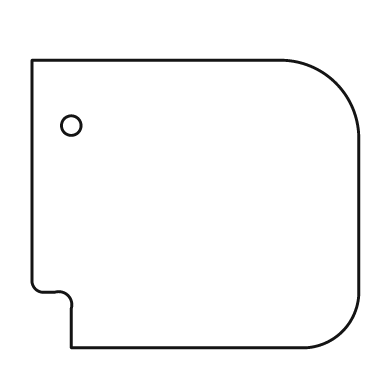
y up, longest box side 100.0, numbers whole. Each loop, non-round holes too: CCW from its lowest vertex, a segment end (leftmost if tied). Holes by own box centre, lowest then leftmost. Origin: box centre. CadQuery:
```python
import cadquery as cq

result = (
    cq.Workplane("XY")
    .moveTo(-38.0, -44.0)
    .lineTo(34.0, -44.0)
    .threePointArc((45.0, -39.0), (50.0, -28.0))
    .lineTo(50.0, 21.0)
    .threePointArc((43.0, 37.0), (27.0, 44.0))
    .lineTo(-50.0, 44.0)
    .lineTo(-50.0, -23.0)
    .threePointArc((-49.0, -26.0), (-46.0, -27.0))
    .lineTo(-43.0, -27.0)
    .threePointArc((-39.0, -28.0), (-38.0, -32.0))
    .close()
    .moveTo(-38.0, 24.0)
    .circle(3.0)
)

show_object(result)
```